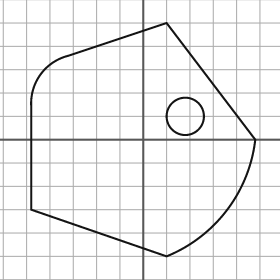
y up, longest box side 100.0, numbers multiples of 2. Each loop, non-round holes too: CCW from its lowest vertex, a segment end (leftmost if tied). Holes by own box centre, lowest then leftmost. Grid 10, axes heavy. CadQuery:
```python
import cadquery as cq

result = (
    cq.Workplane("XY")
    .moveTo(10.0, -50.0)
    .threePointArc((36.0, -30.0), (48.0, 0.0))
    .lineTo(10.0, 50.0)
    .lineTo(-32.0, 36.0)
    .threePointArc((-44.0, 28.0), (-48.0, 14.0))
    .lineTo(-48.0, -30.0)
    .close()
    .moveTo(18.0, 10.0)
    .circle(8.0)
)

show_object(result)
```